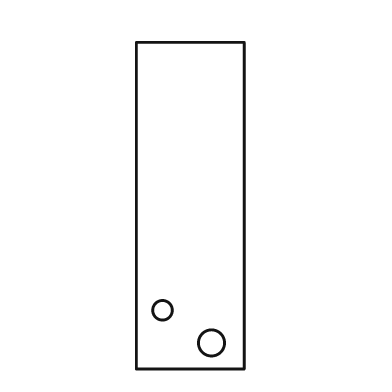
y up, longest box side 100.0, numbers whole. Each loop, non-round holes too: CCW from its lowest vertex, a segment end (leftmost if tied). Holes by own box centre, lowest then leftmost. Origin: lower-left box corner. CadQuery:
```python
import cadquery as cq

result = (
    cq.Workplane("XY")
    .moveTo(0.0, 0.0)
    .lineTo(33.0, 0.0)
    .lineTo(33.0, 100.0)
    .lineTo(0.0, 100.0)
    .close()
    .moveTo(23.0, 8.0)
    .circle(4.0)
    .moveTo(8.0, 18.0)
    .circle(3.0)
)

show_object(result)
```